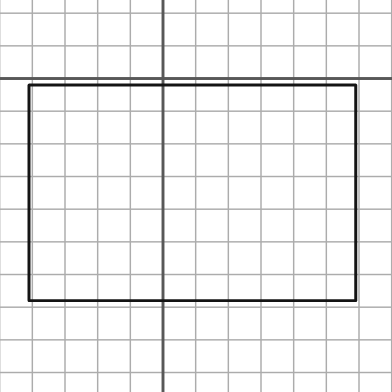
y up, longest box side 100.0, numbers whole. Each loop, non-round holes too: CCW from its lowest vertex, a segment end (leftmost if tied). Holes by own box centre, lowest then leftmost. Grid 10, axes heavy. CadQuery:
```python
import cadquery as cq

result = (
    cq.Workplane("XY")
    .moveTo(-41.0, -68.0)
    .lineTo(59.0, -68.0)
    .lineTo(59.0, -2.0)
    .lineTo(-41.0, -2.0)
    .close()
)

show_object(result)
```